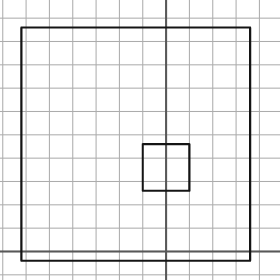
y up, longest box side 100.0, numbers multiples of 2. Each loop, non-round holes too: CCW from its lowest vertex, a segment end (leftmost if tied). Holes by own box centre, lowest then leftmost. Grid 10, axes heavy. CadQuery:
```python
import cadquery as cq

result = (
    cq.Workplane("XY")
    .moveTo(-62.0, -4.0)
    .lineTo(36.0, -4.0)
    .lineTo(36.0, 96.0)
    .lineTo(-62.0, 96.0)
    .close()
    .moveTo(-10.0, 26.0)
    .lineTo(10.0, 26.0)
    .lineTo(10.0, 46.0)
    .lineTo(-10.0, 46.0)
    .close()
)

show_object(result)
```